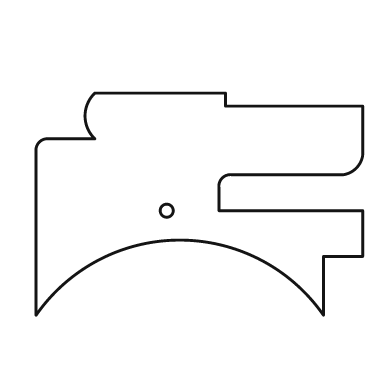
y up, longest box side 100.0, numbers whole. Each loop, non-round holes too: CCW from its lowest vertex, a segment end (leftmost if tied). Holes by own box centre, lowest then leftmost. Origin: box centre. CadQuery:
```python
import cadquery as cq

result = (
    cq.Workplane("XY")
    .moveTo(-50.0, -34.0)
    .threePointArc((-6.0, -11.0), (38.0, -34.0))
    .lineTo(38.0, -16.0)
    .lineTo(50.0, -16.0)
    .lineTo(50.0, -2.0)
    .lineTo(6.0, -2.0)
    .lineTo(6.0, 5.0)
    .threePointArc((7.0, 8.0), (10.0, 9.0))
    .lineTo(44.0, 9.0)
    .threePointArc((48.0, 11.0), (50.0, 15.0))
    .lineTo(50.0, 30.0)
    .lineTo(8.0, 30.0)
    .lineTo(8.0, 34.0)
    .lineTo(-32.0, 34.0)
    .threePointArc((-35.0, 27.0), (-32.0, 20.0))
    .lineTo(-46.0, 20.0)
    .threePointArc((-49.0, 19.0), (-50.0, 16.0))
    .close()
    .moveTo(-10.0, -2.0)
    .circle(2.0)
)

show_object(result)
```